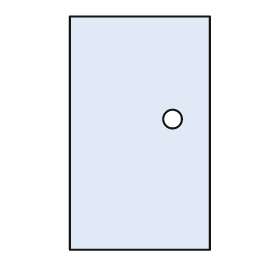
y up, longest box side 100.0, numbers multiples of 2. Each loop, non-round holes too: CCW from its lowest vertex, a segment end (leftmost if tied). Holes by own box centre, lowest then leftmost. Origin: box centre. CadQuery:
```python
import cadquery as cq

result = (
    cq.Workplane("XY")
    .moveTo(-30.0, -50.0)
    .lineTo(30.0, -50.0)
    .lineTo(30.0, 50.0)
    .lineTo(-30.0, 50.0)
    .close()
    .moveTo(14.0, 6.0)
    .circle(4.0)
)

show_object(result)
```